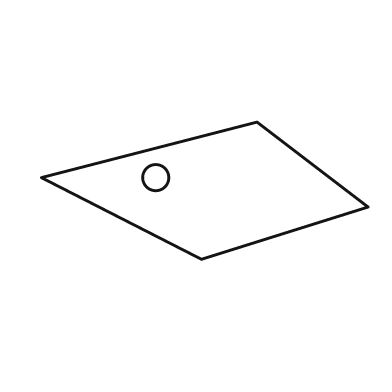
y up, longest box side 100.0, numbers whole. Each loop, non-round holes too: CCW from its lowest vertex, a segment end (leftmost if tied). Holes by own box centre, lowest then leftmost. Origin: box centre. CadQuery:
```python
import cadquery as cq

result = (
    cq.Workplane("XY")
    .moveTo(-1.0, -21.0)
    .lineTo(50.0, -5.0)
    .lineTo(16.0, 21.0)
    .lineTo(-50.0, 4.0)
    .close()
    .moveTo(-15.0, 4.0)
    .circle(4.0)
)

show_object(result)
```